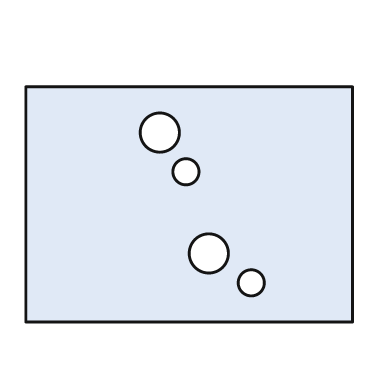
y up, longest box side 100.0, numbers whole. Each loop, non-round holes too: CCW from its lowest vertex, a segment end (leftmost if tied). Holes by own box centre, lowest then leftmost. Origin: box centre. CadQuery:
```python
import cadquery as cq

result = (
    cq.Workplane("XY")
    .moveTo(-50.0, -36.0)
    .lineTo(50.0, -36.0)
    .lineTo(50.0, 36.0)
    .lineTo(-50.0, 36.0)
    .close()
    .moveTo(19.0, -24.0)
    .circle(4.0)
    .moveTo(6.0, -15.0)
    .circle(6.0)
    .moveTo(-1.0, 10.0)
    .circle(4.0)
    .moveTo(-9.0, 22.0)
    .circle(6.0)
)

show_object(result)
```